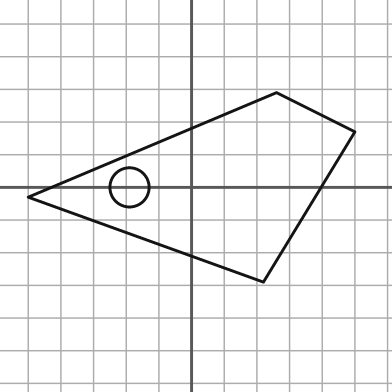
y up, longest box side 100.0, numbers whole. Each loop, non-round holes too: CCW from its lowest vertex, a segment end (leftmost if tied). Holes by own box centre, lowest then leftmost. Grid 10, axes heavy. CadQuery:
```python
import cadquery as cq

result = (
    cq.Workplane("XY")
    .moveTo(22.0, -29.0)
    .lineTo(50.0, 17.0)
    .lineTo(26.0, 29.0)
    .lineTo(-50.0, -3.0)
    .close()
    .moveTo(-19.0, 0.0)
    .circle(6.0)
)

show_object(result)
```